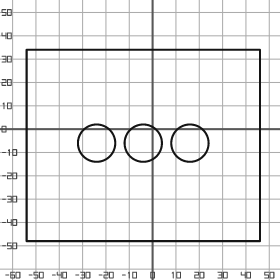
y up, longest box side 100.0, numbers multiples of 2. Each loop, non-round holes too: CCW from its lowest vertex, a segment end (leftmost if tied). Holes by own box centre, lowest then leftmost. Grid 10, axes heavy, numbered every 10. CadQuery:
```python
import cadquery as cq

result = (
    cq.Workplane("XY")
    .moveTo(-54.0, -48.0)
    .lineTo(46.0, -48.0)
    .lineTo(46.0, 34.0)
    .lineTo(-54.0, 34.0)
    .close()
    .moveTo(-24.0, -6.0)
    .circle(8.0)
    .moveTo(-4.0, -6.0)
    .circle(8.0)
    .moveTo(16.0, -6.0)
    .circle(8.0)
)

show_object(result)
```